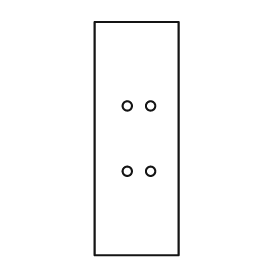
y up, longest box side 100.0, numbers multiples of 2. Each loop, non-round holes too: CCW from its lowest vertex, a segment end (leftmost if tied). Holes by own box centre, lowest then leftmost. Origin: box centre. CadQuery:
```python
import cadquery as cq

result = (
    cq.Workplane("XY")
    .moveTo(-18.0, -50.0)
    .lineTo(18.0, -50.0)
    .lineTo(18.0, 50.0)
    .lineTo(-18.0, 50.0)
    .close()
    .moveTo(-4.0, -14.0)
    .circle(2.0)
    .moveTo(6.0, -14.0)
    .circle(2.0)
    .moveTo(-4.0, 14.0)
    .circle(2.0)
    .moveTo(6.0, 14.0)
    .circle(2.0)
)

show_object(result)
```